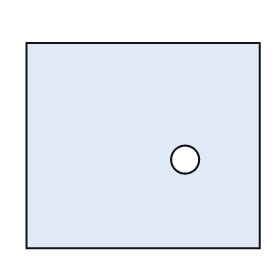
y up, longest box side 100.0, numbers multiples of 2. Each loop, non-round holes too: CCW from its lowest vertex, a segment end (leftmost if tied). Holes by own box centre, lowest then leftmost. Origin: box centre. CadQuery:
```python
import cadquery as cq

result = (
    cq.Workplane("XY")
    .moveTo(-50.0, -44.0)
    .lineTo(50.0, -44.0)
    .lineTo(50.0, 44.0)
    .lineTo(-50.0, 44.0)
    .close()
    .moveTo(18.0, -6.0)
    .circle(6.0)
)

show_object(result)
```